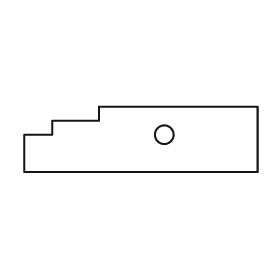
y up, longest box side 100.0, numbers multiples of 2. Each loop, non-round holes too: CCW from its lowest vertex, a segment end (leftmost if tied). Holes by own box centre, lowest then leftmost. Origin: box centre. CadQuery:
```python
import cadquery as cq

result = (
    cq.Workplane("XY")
    .moveTo(-50.0, -14.0)
    .lineTo(50.0, -14.0)
    .lineTo(50.0, 14.0)
    .lineTo(-18.0, 14.0)
    .lineTo(-18.0, 8.0)
    .lineTo(-38.0, 8.0)
    .lineTo(-38.0, 2.0)
    .lineTo(-50.0, 2.0)
    .close()
    .moveTo(10.0, 2.0)
    .circle(4.0)
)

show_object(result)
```